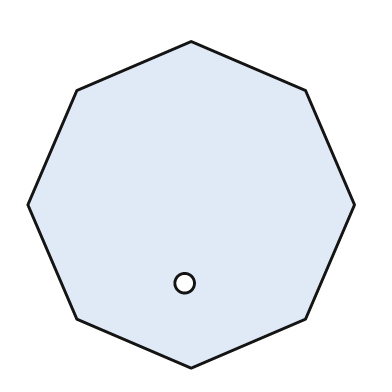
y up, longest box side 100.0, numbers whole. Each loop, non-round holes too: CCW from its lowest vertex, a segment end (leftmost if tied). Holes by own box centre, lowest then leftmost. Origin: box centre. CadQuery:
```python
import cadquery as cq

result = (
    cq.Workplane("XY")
    .moveTo(0.0, -50.0)
    .lineTo(35.0, -35.0)
    .lineTo(50.0, 0.0)
    .lineTo(35.0, 35.0)
    .lineTo(0.0, 50.0)
    .lineTo(-35.0, 35.0)
    .lineTo(-50.0, 0.0)
    .lineTo(-35.0, -35.0)
    .close()
    .moveTo(-2.0, -24.0)
    .circle(3.0)
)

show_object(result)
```